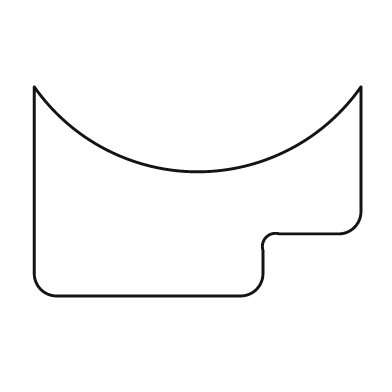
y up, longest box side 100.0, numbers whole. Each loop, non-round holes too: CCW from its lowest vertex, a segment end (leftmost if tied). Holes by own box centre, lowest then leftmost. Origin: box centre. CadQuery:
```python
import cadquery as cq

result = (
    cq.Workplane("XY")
    .moveTo(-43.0, -32.0)
    .lineTo(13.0, -32.0)
    .threePointArc((18.0, -30.0), (20.0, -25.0))
    .lineTo(20.0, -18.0)
    .threePointArc((21.0, -14.0), (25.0, -13.0))
    .lineTo(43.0, -13.0)
    .threePointArc((48.0, -11.0), (50.0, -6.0))
    .lineTo(50.0, 32.0)
    .threePointArc((0.0, 6.0), (-50.0, 32.0))
    .lineTo(-50.0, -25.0)
    .threePointArc((-48.0, -30.0), (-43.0, -32.0))
    .close()
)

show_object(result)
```